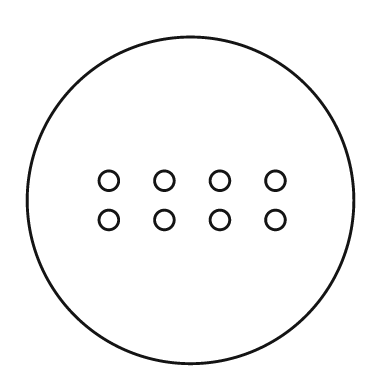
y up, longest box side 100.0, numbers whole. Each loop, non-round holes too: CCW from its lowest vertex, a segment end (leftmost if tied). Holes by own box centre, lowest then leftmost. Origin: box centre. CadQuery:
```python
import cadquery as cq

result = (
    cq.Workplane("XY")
    .moveTo(0.0, 0.0)
    .circle(50.0)
    .moveTo(-25.0, -6.0)
    .circle(3.0)
    .moveTo(-8.0, -6.0)
    .circle(3.0)
    .moveTo(9.0, -6.0)
    .circle(3.0)
    .moveTo(26.0, -6.0)
    .circle(3.0)
    .moveTo(-25.0, 6.0)
    .circle(3.0)
    .moveTo(-8.0, 6.0)
    .circle(3.0)
    .moveTo(9.0, 6.0)
    .circle(3.0)
    .moveTo(26.0, 6.0)
    .circle(3.0)
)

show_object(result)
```